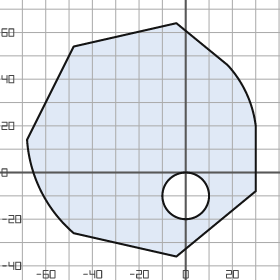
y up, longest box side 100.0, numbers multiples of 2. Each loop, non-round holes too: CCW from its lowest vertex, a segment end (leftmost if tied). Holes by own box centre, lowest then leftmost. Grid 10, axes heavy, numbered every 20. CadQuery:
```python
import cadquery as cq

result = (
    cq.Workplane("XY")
    .moveTo(-4.0, -36.0)
    .lineTo(30.0, -8.0)
    .lineTo(30.0, 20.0)
    .threePointArc((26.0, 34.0), (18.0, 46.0))
    .lineTo(-4.0, 64.0)
    .lineTo(-48.0, 54.0)
    .lineTo(-68.0, 14.0)
    .threePointArc((-62.0, -8.0), (-48.0, -26.0))
    .close()
    .moveTo(0.0, -10.0)
    .circle(10.0)
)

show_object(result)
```